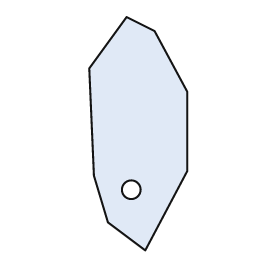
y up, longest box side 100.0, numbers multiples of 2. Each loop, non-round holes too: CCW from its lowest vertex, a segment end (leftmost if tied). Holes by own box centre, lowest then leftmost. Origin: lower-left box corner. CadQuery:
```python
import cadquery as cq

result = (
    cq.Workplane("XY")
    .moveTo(24.0, 0.0)
    .lineTo(42.0, 34.0)
    .lineTo(42.0, 68.0)
    .lineTo(28.0, 94.0)
    .lineTo(16.0, 100.0)
    .lineTo(0.0, 78.0)
    .lineTo(2.0, 32.0)
    .lineTo(8.0, 12.0)
    .close()
    .moveTo(18.0, 26.0)
    .circle(4.0)
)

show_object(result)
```